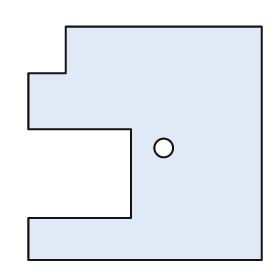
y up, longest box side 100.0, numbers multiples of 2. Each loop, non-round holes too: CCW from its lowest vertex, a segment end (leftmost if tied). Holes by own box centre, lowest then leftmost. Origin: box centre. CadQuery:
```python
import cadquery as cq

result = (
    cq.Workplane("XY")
    .moveTo(-50.0, -50.0)
    .lineTo(50.0, -50.0)
    .lineTo(50.0, 50.0)
    .lineTo(-34.0, 50.0)
    .lineTo(-34.0, 30.0)
    .lineTo(-50.0, 30.0)
    .lineTo(-50.0, 6.0)
    .lineTo(-6.0, 6.0)
    .lineTo(-6.0, -32.0)
    .lineTo(-50.0, -32.0)
    .close()
    .moveTo(8.0, -2.0)
    .circle(4.0)
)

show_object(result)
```